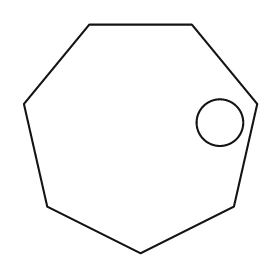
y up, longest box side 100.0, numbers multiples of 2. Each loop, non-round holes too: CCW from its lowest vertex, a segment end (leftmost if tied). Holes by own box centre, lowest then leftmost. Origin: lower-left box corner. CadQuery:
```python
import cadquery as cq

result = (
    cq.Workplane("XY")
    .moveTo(50.0, 0.0)
    .lineTo(90.0, 20.0)
    .lineTo(100.0, 64.0)
    .lineTo(72.0, 98.0)
    .lineTo(28.0, 98.0)
    .lineTo(0.0, 64.0)
    .lineTo(10.0, 20.0)
    .close()
    .moveTo(84.0, 56.0)
    .circle(10.0)
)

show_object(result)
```